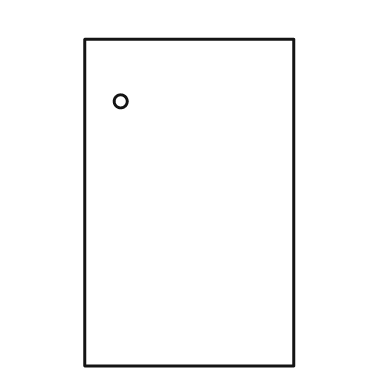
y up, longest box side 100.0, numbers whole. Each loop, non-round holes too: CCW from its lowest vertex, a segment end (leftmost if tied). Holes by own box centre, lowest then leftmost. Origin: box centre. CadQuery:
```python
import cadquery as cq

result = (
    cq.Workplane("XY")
    .moveTo(-32.0, -50.0)
    .lineTo(32.0, -50.0)
    .lineTo(32.0, 50.0)
    .lineTo(-32.0, 50.0)
    .close()
    .moveTo(-21.0, 31.0)
    .circle(2.0)
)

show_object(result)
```